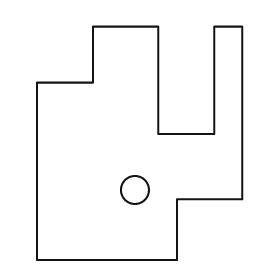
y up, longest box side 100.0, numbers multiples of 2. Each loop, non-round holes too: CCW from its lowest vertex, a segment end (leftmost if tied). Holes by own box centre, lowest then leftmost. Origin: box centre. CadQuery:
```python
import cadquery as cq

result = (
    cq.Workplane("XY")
    .moveTo(-44.0, -50.0)
    .lineTo(16.0, -50.0)
    .lineTo(16.0, -24.0)
    .lineTo(44.0, -24.0)
    .lineTo(44.0, 50.0)
    .lineTo(32.0, 50.0)
    .lineTo(32.0, 4.0)
    .lineTo(8.0, 4.0)
    .lineTo(8.0, 50.0)
    .lineTo(-20.0, 50.0)
    .lineTo(-20.0, 26.0)
    .lineTo(-44.0, 26.0)
    .close()
    .moveTo(-2.0, -20.0)
    .circle(6.0)
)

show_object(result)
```